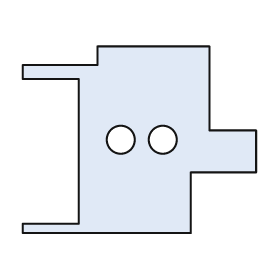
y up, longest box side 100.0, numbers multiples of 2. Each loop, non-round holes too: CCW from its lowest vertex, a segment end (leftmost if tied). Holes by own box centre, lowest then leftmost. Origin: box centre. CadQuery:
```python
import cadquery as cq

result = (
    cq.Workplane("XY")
    .moveTo(-50.0, -40.0)
    .lineTo(22.0, -40.0)
    .lineTo(22.0, -14.0)
    .lineTo(50.0, -14.0)
    .lineTo(50.0, 4.0)
    .lineTo(30.0, 4.0)
    .lineTo(30.0, 40.0)
    .lineTo(-18.0, 40.0)
    .lineTo(-18.0, 32.0)
    .lineTo(-50.0, 32.0)
    .lineTo(-50.0, 26.0)
    .lineTo(-26.0, 26.0)
    .lineTo(-26.0, -36.0)
    .lineTo(-50.0, -36.0)
    .close()
    .moveTo(-8.0, 0.0)
    .circle(6.0)
    .moveTo(10.0, 0.0)
    .circle(6.0)
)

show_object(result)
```